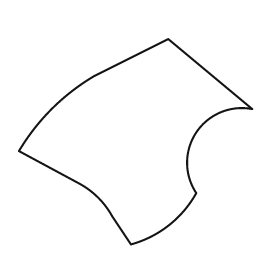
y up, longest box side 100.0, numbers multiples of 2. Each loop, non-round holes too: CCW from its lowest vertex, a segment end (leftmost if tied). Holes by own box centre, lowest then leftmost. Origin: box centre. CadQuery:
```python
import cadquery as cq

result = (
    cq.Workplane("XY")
    .moveTo(-2.0, -44.0)
    .threePointArc((14.0, -36.0), (26.0, -22.0))
    .threePointArc((26.0, 4.0), (50.0, 14.0))
    .lineTo(14.0, 44.0)
    .lineTo(-18.0, 28.0)
    .threePointArc((-36.0, 14.0), (-50.0, -4.0))
    .lineTo(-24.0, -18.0)
    .threePointArc((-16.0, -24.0), (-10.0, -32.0))
    .close()
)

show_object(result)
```